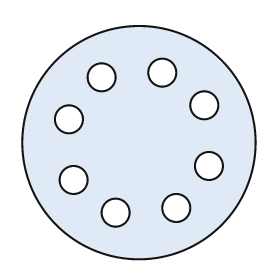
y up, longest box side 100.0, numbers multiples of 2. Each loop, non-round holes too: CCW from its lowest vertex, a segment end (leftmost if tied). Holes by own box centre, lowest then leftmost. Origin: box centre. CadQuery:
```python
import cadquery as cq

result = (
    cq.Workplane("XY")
    .moveTo(0.0, 0.0)
    .circle(50.0)
    .moveTo(-10.0, -30.0)
    .circle(6.0)
    .moveTo(16.0, -28.0)
    .circle(6.0)
    .moveTo(-28.0, -16.0)
    .circle(6.0)
    .moveTo(30.0, -10.0)
    .circle(6.0)
    .moveTo(-30.0, 10.0)
    .circle(6.0)
    .moveTo(28.0, 16.0)
    .circle(6.0)
    .moveTo(-16.0, 28.0)
    .circle(6.0)
    .moveTo(10.0, 30.0)
    .circle(6.0)
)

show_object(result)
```